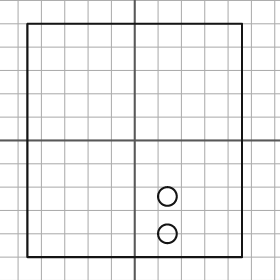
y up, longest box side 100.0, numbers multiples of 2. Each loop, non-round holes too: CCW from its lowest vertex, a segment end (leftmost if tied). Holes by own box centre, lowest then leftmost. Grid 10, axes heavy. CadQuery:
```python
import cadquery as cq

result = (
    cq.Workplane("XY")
    .moveTo(-46.0, -50.0)
    .lineTo(46.0, -50.0)
    .lineTo(46.0, 50.0)
    .lineTo(-46.0, 50.0)
    .close()
    .moveTo(14.0, -40.0)
    .circle(4.0)
    .moveTo(14.0, -24.0)
    .circle(4.0)
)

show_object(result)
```